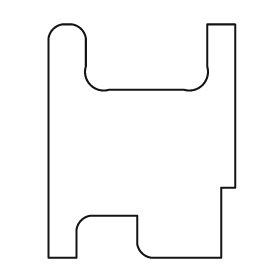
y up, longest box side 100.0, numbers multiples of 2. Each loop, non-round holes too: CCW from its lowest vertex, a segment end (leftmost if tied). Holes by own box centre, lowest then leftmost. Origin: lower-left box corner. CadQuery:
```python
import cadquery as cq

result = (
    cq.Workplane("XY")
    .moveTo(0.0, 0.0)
    .lineTo(12.0, 0.0)
    .lineTo(12.0, 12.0)
    .threePointArc((14.0, 16.0), (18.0, 18.0))
    .lineTo(38.0, 18.0)
    .lineTo(38.0, 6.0)
    .threePointArc((40.0, 2.0), (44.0, 0.0))
    .lineTo(74.0, 0.0)
    .lineTo(74.0, 30.0)
    .lineTo(80.0, 30.0)
    .lineTo(80.0, 100.0)
    .lineTo(68.0, 100.0)
    .lineTo(68.0, 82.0)
    .threePointArc((66.0, 74.0), (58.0, 72.0))
    .lineTo(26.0, 72.0)
    .threePointArc((18.0, 74.0), (16.0, 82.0))
    .lineTo(16.0, 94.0)
    .threePointArc((14.0, 98.0), (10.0, 100.0))
    .lineTo(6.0, 100.0)
    .threePointArc((2.0, 98.0), (0.0, 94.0))
    .close()
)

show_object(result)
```